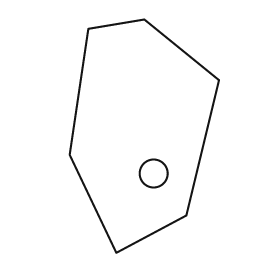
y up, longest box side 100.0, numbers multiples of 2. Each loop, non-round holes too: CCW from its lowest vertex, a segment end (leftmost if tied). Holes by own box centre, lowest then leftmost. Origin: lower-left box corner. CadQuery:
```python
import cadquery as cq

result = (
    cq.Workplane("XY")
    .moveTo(20.0, 0.0)
    .lineTo(50.0, 16.0)
    .lineTo(64.0, 74.0)
    .lineTo(32.0, 100.0)
    .lineTo(8.0, 96.0)
    .lineTo(0.0, 42.0)
    .close()
    .moveTo(36.0, 34.0)
    .circle(6.0)
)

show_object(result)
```